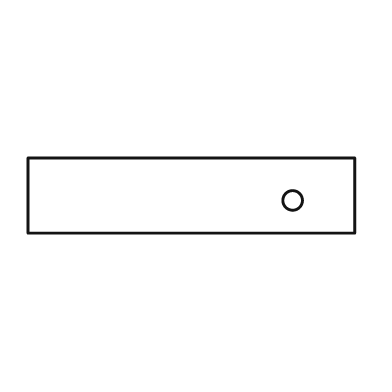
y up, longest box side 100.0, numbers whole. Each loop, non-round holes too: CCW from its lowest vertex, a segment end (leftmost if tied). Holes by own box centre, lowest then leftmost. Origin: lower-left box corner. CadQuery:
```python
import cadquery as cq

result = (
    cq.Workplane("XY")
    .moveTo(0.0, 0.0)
    .lineTo(100.0, 0.0)
    .lineTo(100.0, 23.0)
    .lineTo(0.0, 23.0)
    .close()
    .moveTo(81.0, 10.0)
    .circle(3.0)
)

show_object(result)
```